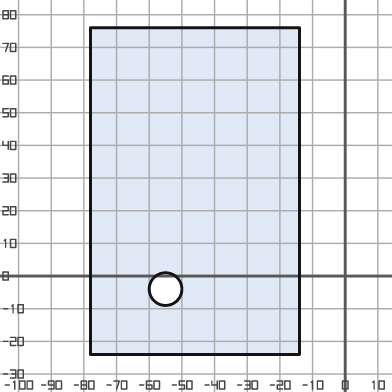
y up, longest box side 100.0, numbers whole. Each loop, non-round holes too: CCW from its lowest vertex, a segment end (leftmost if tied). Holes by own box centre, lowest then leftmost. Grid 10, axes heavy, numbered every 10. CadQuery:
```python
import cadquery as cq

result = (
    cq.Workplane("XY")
    .moveTo(-78.0, -24.0)
    .lineTo(-14.0, -24.0)
    .lineTo(-14.0, 76.0)
    .lineTo(-78.0, 76.0)
    .close()
    .moveTo(-55.0, -4.0)
    .circle(5.0)
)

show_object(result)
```